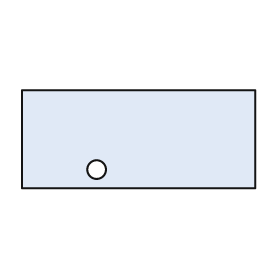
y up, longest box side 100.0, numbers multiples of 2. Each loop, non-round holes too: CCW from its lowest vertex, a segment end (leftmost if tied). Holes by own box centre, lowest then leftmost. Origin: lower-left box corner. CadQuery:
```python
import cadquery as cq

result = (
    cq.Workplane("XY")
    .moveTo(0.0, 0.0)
    .lineTo(100.0, 0.0)
    .lineTo(100.0, 42.0)
    .lineTo(0.0, 42.0)
    .close()
    .moveTo(32.0, 8.0)
    .circle(4.0)
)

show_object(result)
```